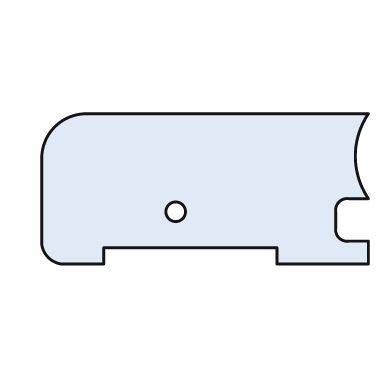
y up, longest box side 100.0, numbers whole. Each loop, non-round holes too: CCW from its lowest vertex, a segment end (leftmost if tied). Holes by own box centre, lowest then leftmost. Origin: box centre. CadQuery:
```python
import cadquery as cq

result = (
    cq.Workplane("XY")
    .moveTo(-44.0, -23.0)
    .lineTo(-31.0, -23.0)
    .lineTo(-31.0, -18.0)
    .lineTo(22.0, -18.0)
    .lineTo(22.0, -23.0)
    .lineTo(50.0, -23.0)
    .lineTo(50.0, -16.0)
    .lineTo(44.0, -16.0)
    .threePointArc((41.0, -15.0), (40.0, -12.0))
    .lineTo(40.0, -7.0)
    .threePointArc((41.0, -4.0), (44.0, -3.0))
    .lineTo(50.0, -3.0)
    .threePointArc((46.0, 10.0), (50.0, 23.0))
    .lineTo(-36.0, 23.0)
    .threePointArc((-46.0, 19.0), (-50.0, 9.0))
    .lineTo(-50.0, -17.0)
    .threePointArc((-48.0, -21.0), (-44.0, -23.0))
    .close()
    .moveTo(-9.0, -7.0)
    .circle(3.0)
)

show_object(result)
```